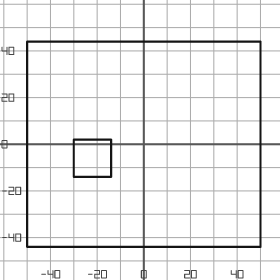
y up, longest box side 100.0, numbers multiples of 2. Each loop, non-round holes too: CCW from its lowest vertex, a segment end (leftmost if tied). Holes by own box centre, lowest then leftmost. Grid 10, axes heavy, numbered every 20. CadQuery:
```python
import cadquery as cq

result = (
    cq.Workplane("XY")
    .moveTo(-50.0, -44.0)
    .lineTo(50.0, -44.0)
    .lineTo(50.0, 44.0)
    .lineTo(-50.0, 44.0)
    .close()
    .moveTo(-30.0, -14.0)
    .lineTo(-14.0, -14.0)
    .lineTo(-14.0, 2.0)
    .lineTo(-30.0, 2.0)
    .close()
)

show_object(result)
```